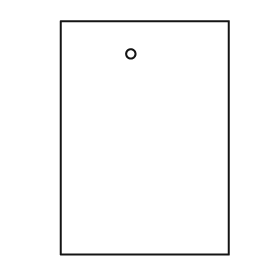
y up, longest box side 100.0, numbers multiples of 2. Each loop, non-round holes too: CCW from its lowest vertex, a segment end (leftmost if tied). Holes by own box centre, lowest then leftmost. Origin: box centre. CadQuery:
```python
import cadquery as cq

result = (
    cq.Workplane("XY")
    .moveTo(-36.0, -50.0)
    .lineTo(36.0, -50.0)
    .lineTo(36.0, 50.0)
    .lineTo(-36.0, 50.0)
    .close()
    .moveTo(-6.0, 36.0)
    .circle(2.0)
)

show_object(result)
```